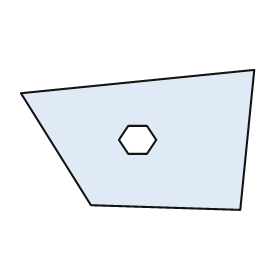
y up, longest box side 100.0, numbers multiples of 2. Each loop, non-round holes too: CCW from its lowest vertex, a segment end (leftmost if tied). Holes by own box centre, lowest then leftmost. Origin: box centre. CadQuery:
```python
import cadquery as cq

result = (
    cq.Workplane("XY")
    .moveTo(44.0, -30.0)
    .lineTo(50.0, 30.0)
    .lineTo(-50.0, 20.0)
    .lineTo(-20.0, -28.0)
    .close()
    .moveTo(-4.0, -6.0)
    .lineTo(4.0, -6.0)
    .lineTo(8.0, 0.0)
    .lineTo(4.0, 6.0)
    .lineTo(-4.0, 6.0)
    .lineTo(-8.0, 0.0)
    .close()
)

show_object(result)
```